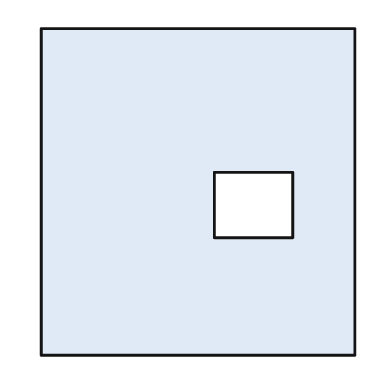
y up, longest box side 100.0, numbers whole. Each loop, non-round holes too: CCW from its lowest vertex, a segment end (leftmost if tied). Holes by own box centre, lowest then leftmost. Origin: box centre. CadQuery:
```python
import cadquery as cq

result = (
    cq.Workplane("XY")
    .moveTo(-48.0, -50.0)
    .lineTo(48.0, -50.0)
    .lineTo(48.0, 50.0)
    .lineTo(-48.0, 50.0)
    .close()
    .moveTo(5.0, -14.0)
    .lineTo(29.0, -14.0)
    .lineTo(29.0, 6.0)
    .lineTo(5.0, 6.0)
    .close()
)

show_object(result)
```